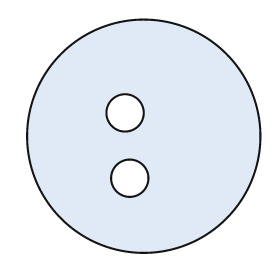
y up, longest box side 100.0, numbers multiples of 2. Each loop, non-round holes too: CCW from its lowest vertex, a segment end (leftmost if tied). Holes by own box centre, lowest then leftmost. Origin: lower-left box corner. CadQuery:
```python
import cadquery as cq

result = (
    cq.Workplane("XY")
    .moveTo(50.0, 50.0)
    .circle(50.0)
    .moveTo(44.0, 32.0)
    .circle(8.0)
    .moveTo(42.0, 60.0)
    .circle(8.0)
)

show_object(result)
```